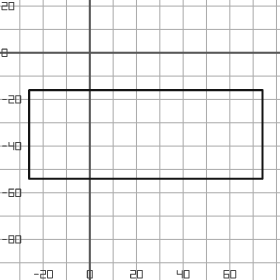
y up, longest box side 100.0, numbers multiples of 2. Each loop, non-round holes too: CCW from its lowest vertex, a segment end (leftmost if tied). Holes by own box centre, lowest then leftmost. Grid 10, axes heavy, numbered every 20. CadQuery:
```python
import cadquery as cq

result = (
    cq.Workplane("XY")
    .moveTo(-26.0, -54.0)
    .lineTo(74.0, -54.0)
    .lineTo(74.0, -16.0)
    .lineTo(-26.0, -16.0)
    .close()
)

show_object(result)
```